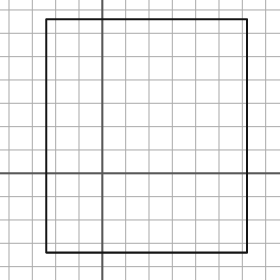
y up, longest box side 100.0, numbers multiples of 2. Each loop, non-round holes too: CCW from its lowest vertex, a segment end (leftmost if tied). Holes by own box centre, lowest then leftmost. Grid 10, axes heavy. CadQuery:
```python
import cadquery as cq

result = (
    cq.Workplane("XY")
    .moveTo(-24.0, -34.0)
    .lineTo(62.0, -34.0)
    .lineTo(62.0, 66.0)
    .lineTo(-24.0, 66.0)
    .close()
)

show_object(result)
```